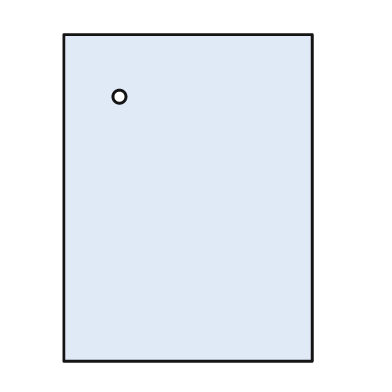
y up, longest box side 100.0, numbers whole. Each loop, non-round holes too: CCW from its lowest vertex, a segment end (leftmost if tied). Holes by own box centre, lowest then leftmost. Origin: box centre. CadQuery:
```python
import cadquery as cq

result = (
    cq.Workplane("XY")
    .moveTo(-38.0, -50.0)
    .lineTo(38.0, -50.0)
    .lineTo(38.0, 50.0)
    .lineTo(-38.0, 50.0)
    .close()
    .moveTo(-21.0, 31.0)
    .circle(2.0)
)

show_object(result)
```